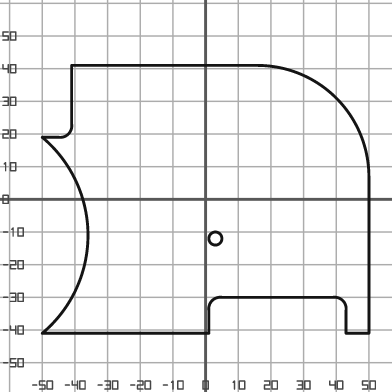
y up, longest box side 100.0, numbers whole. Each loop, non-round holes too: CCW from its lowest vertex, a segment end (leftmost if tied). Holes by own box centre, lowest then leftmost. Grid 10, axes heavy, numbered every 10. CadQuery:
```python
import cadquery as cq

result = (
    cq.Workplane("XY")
    .moveTo(-50.0, -41.0)
    .lineTo(1.0, -41.0)
    .lineTo(1.0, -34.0)
    .threePointArc((2.0, -31.0), (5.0, -30.0))
    .lineTo(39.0, -30.0)
    .threePointArc((42.0, -31.0), (43.0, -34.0))
    .lineTo(43.0, -41.0)
    .lineTo(50.0, -41.0)
    .lineTo(50.0, 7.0)
    .threePointArc((40.0, 31.0), (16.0, 41.0))
    .lineTo(-41.0, 41.0)
    .lineTo(-41.0, 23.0)
    .threePointArc((-42.0, 20.0), (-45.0, 19.0))
    .lineTo(-50.0, 19.0)
    .threePointArc((-36.0, -11.0), (-50.0, -41.0))
    .close()
    .moveTo(3.0, -12.0)
    .circle(2.0)
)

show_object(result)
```